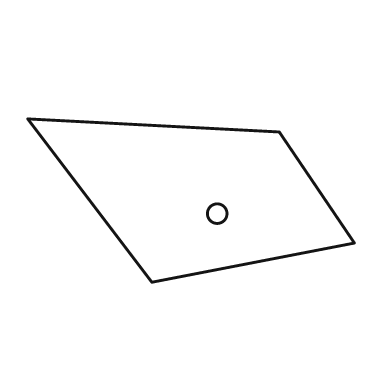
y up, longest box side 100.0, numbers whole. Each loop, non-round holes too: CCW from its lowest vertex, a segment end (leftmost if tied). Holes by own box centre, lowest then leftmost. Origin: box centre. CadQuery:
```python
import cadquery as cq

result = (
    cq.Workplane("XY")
    .moveTo(-12.0, -25.0)
    .lineTo(50.0, -13.0)
    .lineTo(27.0, 21.0)
    .lineTo(-50.0, 25.0)
    .close()
    .moveTo(8.0, -4.0)
    .circle(3.0)
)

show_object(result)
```